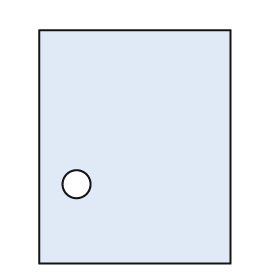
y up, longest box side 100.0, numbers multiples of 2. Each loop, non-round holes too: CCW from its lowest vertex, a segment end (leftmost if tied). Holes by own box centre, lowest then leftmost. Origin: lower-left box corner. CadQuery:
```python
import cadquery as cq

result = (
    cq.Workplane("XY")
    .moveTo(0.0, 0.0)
    .lineTo(82.0, 0.0)
    .lineTo(82.0, 100.0)
    .lineTo(0.0, 100.0)
    .close()
    .moveTo(16.0, 34.0)
    .circle(6.0)
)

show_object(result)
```